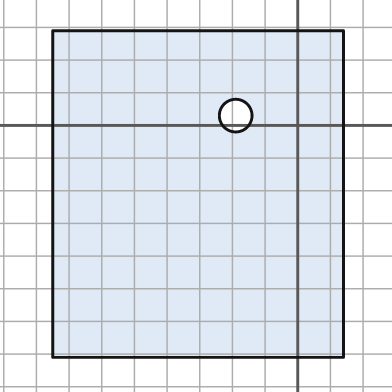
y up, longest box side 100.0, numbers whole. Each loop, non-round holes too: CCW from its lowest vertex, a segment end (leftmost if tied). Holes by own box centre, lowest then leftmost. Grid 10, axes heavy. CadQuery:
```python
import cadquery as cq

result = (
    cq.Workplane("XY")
    .moveTo(-75.0, -71.0)
    .lineTo(14.0, -71.0)
    .lineTo(14.0, 29.0)
    .lineTo(-75.0, 29.0)
    .close()
    .moveTo(-19.0, 3.0)
    .circle(5.0)
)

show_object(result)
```